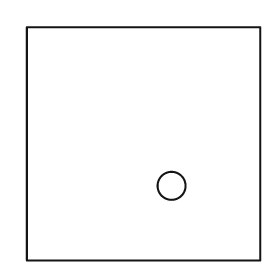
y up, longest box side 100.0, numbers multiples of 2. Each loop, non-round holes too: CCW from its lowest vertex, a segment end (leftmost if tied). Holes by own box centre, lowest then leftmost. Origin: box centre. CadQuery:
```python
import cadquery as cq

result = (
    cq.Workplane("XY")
    .moveTo(-50.0, -50.0)
    .lineTo(50.0, -50.0)
    .lineTo(50.0, 50.0)
    .lineTo(-50.0, 50.0)
    .close()
    .moveTo(12.0, -18.0)
    .circle(6.0)
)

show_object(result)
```